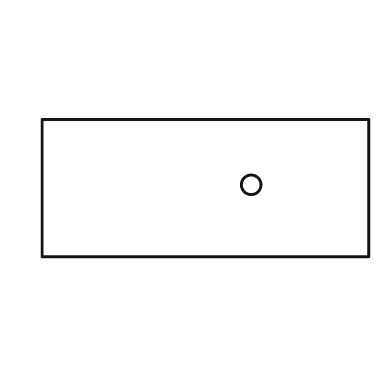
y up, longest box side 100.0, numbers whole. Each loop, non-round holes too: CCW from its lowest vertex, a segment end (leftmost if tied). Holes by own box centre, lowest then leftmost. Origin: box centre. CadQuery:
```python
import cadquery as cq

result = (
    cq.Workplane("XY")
    .moveTo(-50.0, -21.0)
    .lineTo(50.0, -21.0)
    .lineTo(50.0, 21.0)
    .lineTo(-50.0, 21.0)
    .close()
    .moveTo(14.0, 1.0)
    .circle(3.0)
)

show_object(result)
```